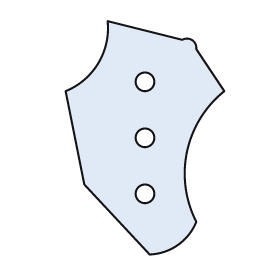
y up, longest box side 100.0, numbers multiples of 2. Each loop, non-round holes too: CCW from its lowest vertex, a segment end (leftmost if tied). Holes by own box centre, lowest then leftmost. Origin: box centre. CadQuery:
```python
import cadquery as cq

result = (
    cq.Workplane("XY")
    .moveTo(2.0, -50.0)
    .threePointArc((14.0, -46.0), (22.0, -36.0))
    .threePointArc((18.0, -6.0), (34.0, 20.0))
    .lineTo(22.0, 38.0)
    .threePointArc((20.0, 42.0), (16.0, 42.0))
    .lineTo(-16.0, 50.0)
    .threePointArc((-20.0, 32.0), (-34.0, 20.0))
    .lineTo(-26.0, -20.0)
    .close()
    .moveTo(0.0, -24.0)
    .circle(4.0)
    .moveTo(0.0, 0.0)
    .circle(4.0)
    .moveTo(0.0, 24.0)
    .circle(4.0)
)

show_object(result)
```